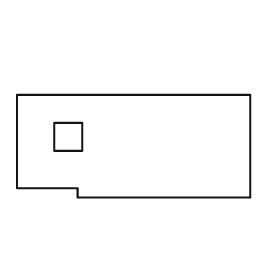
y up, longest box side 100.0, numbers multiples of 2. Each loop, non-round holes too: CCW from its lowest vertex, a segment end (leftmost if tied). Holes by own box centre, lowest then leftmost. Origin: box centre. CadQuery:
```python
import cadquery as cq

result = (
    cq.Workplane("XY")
    .moveTo(-24.0, -22.0)
    .lineTo(50.0, -22.0)
    .lineTo(50.0, 22.0)
    .lineTo(-50.0, 22.0)
    .lineTo(-50.0, -18.0)
    .lineTo(-24.0, -18.0)
    .close()
    .moveTo(-34.0, -2.0)
    .lineTo(-22.0, -2.0)
    .lineTo(-22.0, 10.0)
    .lineTo(-34.0, 10.0)
    .close()
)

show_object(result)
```